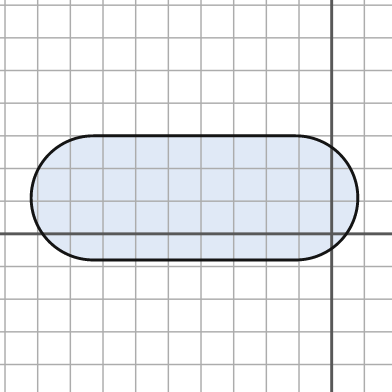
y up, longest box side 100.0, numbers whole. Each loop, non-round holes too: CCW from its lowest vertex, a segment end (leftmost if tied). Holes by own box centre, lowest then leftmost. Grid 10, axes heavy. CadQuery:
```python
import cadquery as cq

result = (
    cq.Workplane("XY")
    .moveTo(-73.0, -8.0)
    .lineTo(-11.0, -8.0)
    .threePointArc((8.0, 11.0), (-11.0, 30.0))
    .lineTo(-73.0, 30.0)
    .threePointArc((-92.0, 11.0), (-73.0, -8.0))
    .close()
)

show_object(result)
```